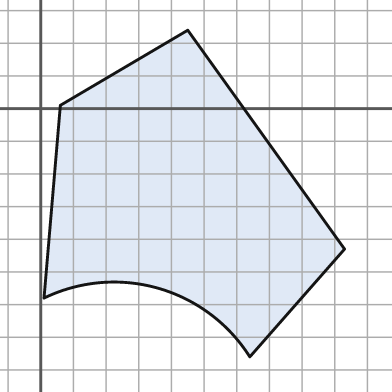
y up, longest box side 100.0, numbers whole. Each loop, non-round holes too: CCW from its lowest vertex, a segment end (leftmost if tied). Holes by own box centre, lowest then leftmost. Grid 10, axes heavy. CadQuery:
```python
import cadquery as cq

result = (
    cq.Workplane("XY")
    .moveTo(64.0, -76.0)
    .lineTo(93.0, -43.0)
    .lineTo(45.0, 24.0)
    .lineTo(6.0, 1.0)
    .lineTo(1.0, -58.0)
    .threePointArc((36.0, -55.0), (64.0, -76.0))
    .close()
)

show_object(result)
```